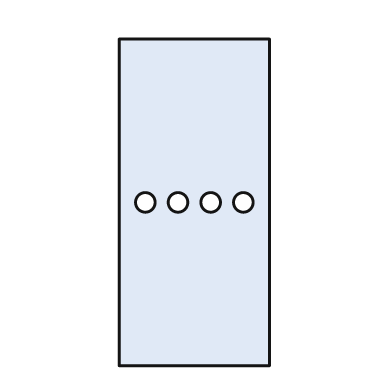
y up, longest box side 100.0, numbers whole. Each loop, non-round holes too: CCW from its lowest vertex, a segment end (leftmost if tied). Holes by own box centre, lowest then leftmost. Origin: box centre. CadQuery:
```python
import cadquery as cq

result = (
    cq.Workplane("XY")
    .moveTo(-23.0, -50.0)
    .lineTo(23.0, -50.0)
    .lineTo(23.0, 50.0)
    .lineTo(-23.0, 50.0)
    .close()
    .moveTo(-15.0, 0.0)
    .circle(3.0)
    .moveTo(-5.0, 0.0)
    .circle(3.0)
    .moveTo(5.0, 0.0)
    .circle(3.0)
    .moveTo(15.0, 0.0)
    .circle(3.0)
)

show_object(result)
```